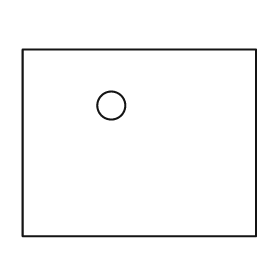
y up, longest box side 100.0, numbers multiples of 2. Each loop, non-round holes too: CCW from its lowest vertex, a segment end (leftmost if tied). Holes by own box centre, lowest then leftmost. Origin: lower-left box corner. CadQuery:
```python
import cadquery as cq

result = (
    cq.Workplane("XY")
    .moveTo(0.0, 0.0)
    .lineTo(100.0, 0.0)
    .lineTo(100.0, 80.0)
    .lineTo(0.0, 80.0)
    .close()
    .moveTo(38.0, 56.0)
    .circle(6.0)
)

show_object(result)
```